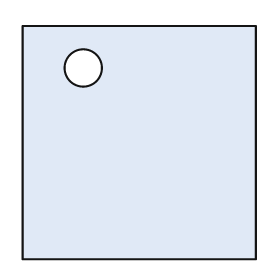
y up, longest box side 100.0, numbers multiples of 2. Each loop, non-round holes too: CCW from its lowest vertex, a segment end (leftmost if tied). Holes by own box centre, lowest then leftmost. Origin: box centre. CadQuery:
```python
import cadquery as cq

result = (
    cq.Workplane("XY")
    .moveTo(-50.0, -50.0)
    .lineTo(50.0, -50.0)
    .lineTo(50.0, 50.0)
    .lineTo(-50.0, 50.0)
    .close()
    .moveTo(-24.0, 32.0)
    .circle(8.0)
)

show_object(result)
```